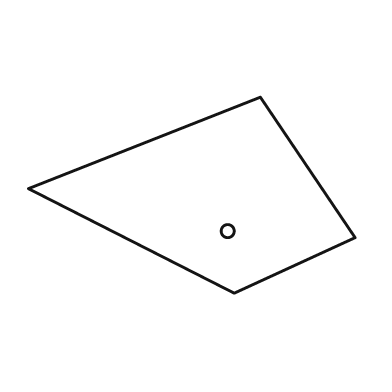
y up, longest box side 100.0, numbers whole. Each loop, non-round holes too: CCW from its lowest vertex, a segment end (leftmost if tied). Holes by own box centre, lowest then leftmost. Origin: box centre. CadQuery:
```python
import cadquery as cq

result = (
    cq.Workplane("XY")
    .moveTo(13.0, -30.0)
    .lineTo(50.0, -13.0)
    .lineTo(21.0, 30.0)
    .lineTo(-50.0, 2.0)
    .close()
    .moveTo(11.0, -11.0)
    .circle(2.0)
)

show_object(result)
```